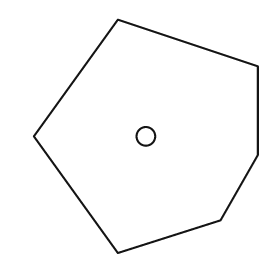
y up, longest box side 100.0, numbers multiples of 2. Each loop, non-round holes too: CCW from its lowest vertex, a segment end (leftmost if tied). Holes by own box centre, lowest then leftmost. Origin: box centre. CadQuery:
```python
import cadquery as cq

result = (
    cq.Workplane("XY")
    .moveTo(-12.0, -50.0)
    .lineTo(32.0, -36.0)
    .lineTo(48.0, -8.0)
    .lineTo(48.0, 30.0)
    .lineTo(-12.0, 50.0)
    .lineTo(-48.0, 0.0)
    .close()
    .moveTo(0.0, 0.0)
    .circle(4.0)
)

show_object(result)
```